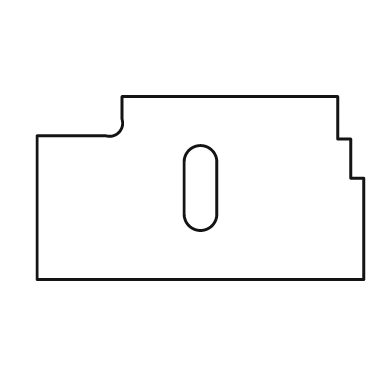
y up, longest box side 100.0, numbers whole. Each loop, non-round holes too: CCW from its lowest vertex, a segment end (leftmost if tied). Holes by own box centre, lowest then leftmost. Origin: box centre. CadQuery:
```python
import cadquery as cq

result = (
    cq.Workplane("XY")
    .moveTo(-50.0, -28.0)
    .lineTo(50.0, -28.0)
    .lineTo(50.0, 3.0)
    .lineTo(46.0, 3.0)
    .lineTo(46.0, 15.0)
    .lineTo(42.0, 15.0)
    .lineTo(42.0, 28.0)
    .lineTo(-24.0, 28.0)
    .lineTo(-24.0, 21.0)
    .threePointArc((-25.0, 17.0), (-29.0, 16.0))
    .lineTo(-50.0, 16.0)
    .close()
    .moveTo(-5.0, -8.0)
    .threePointArc((0.0, -13.0), (5.0, -8.0))
    .lineTo(5.0, 8.0)
    .threePointArc((0.0, 13.0), (-5.0, 8.0))
    .close()
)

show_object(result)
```